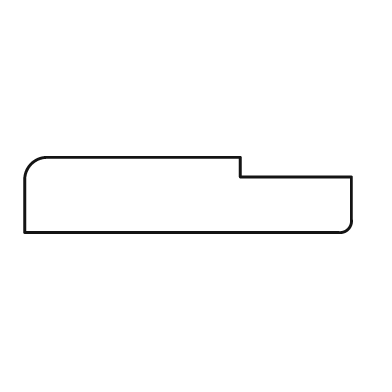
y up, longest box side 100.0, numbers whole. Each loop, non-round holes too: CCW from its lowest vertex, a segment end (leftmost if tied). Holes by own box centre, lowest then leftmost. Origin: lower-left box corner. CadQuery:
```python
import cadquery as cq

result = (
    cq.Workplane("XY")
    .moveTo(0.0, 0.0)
    .lineTo(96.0, 0.0)
    .threePointArc((99.0, 1.0), (100.0, 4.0))
    .lineTo(100.0, 17.0)
    .lineTo(66.0, 17.0)
    .lineTo(66.0, 23.0)
    .lineTo(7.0, 23.0)
    .threePointArc((2.0, 21.0), (0.0, 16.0))
    .close()
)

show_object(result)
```